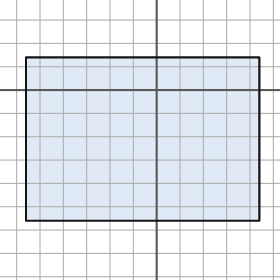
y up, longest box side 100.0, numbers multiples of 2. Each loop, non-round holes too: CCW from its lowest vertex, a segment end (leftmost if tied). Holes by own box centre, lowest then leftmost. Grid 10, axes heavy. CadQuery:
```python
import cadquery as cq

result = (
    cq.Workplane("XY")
    .moveTo(-56.0, -56.0)
    .lineTo(44.0, -56.0)
    .lineTo(44.0, 14.0)
    .lineTo(-56.0, 14.0)
    .close()
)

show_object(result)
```